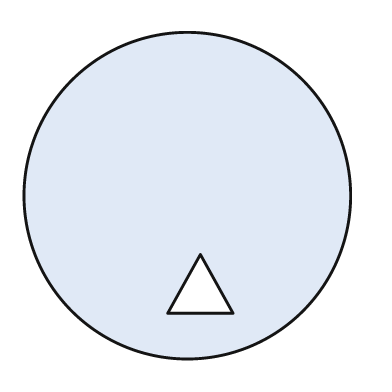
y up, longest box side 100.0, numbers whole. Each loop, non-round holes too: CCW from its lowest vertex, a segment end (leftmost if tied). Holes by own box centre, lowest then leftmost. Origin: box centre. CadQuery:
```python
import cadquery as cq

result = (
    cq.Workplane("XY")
    .moveTo(0.0, 0.0)
    .circle(50.0)
    .moveTo(-6.0, -36.0)
    .lineTo(14.0, -36.0)
    .lineTo(4.0, -18.0)
    .close()
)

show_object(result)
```